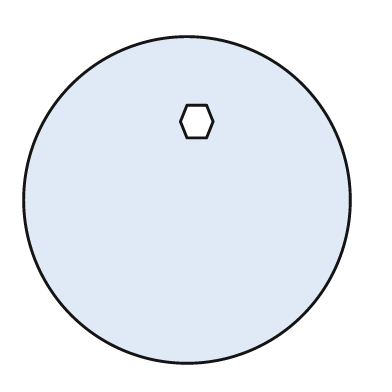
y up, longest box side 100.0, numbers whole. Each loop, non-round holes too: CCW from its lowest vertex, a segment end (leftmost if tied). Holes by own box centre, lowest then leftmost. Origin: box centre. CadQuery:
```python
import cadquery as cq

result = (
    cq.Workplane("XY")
    .moveTo(0.0, 0.0)
    .circle(50.0)
    .moveTo(0.0, 19.0)
    .lineTo(6.0, 19.0)
    .lineTo(8.0, 24.0)
    .lineTo(6.0, 29.0)
    .lineTo(0.0, 29.0)
    .lineTo(-2.0, 24.0)
    .close()
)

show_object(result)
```